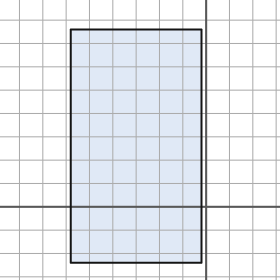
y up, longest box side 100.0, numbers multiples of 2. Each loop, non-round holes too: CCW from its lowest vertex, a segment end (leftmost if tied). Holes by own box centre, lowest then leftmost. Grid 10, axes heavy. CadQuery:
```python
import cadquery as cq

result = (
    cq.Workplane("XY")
    .moveTo(-58.0, -24.0)
    .lineTo(-2.0, -24.0)
    .lineTo(-2.0, 76.0)
    .lineTo(-58.0, 76.0)
    .close()
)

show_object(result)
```